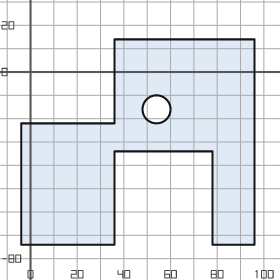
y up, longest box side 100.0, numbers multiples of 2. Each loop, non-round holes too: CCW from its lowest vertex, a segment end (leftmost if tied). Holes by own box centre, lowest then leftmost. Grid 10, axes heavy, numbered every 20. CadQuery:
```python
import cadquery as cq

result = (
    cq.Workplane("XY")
    .moveTo(-4.0, -74.0)
    .lineTo(36.0, -74.0)
    .lineTo(36.0, -34.0)
    .lineTo(78.0, -34.0)
    .lineTo(78.0, -74.0)
    .lineTo(96.0, -74.0)
    .lineTo(96.0, 14.0)
    .lineTo(36.0, 14.0)
    .lineTo(36.0, -22.0)
    .lineTo(-4.0, -22.0)
    .close()
    .moveTo(54.0, -16.0)
    .circle(6.0)
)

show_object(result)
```